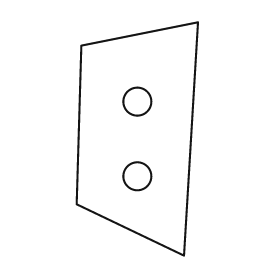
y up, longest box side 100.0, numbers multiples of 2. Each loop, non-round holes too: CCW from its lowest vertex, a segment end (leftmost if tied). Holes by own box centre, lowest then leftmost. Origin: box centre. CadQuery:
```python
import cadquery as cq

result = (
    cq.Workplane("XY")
    .moveTo(20.0, -50.0)
    .lineTo(26.0, 50.0)
    .lineTo(-24.0, 40.0)
    .lineTo(-26.0, -28.0)
    .close()
    .moveTo(0.0, -16.0)
    .circle(6.0)
    .moveTo(0.0, 16.0)
    .circle(6.0)
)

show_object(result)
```